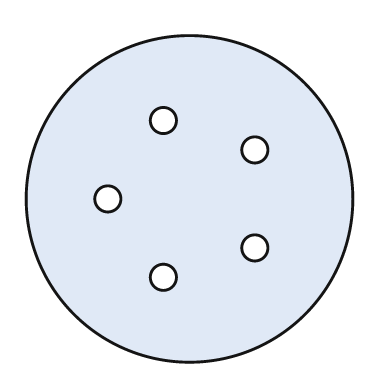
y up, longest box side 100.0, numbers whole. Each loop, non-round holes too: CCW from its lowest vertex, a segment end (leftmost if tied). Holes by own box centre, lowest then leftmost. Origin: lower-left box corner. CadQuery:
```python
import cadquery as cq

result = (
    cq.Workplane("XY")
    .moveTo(50.0, 50.0)
    .circle(50.0)
    .moveTo(42.0, 26.0)
    .circle(4.0)
    .moveTo(70.0, 35.0)
    .circle(4.0)
    .moveTo(25.0, 50.0)
    .circle(4.0)
    .moveTo(70.0, 65.0)
    .circle(4.0)
    .moveTo(42.0, 74.0)
    .circle(4.0)
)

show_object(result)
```